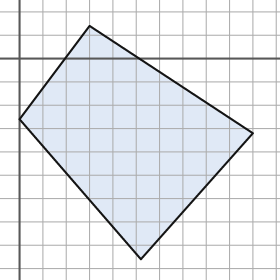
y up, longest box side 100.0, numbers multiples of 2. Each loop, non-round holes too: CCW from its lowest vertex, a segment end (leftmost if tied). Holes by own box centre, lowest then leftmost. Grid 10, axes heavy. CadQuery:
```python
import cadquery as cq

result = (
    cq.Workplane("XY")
    .moveTo(52.0, -86.0)
    .lineTo(100.0, -32.0)
    .lineTo(30.0, 14.0)
    .lineTo(0.0, -26.0)
    .close()
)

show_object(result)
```